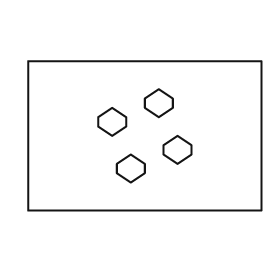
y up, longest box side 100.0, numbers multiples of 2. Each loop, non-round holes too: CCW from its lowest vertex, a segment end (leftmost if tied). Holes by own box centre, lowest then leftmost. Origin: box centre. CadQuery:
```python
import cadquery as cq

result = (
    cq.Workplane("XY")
    .moveTo(-50.0, -32.0)
    .lineTo(50.0, -32.0)
    .lineTo(50.0, 32.0)
    .lineTo(-50.0, 32.0)
    .close()
    .moveTo(-6.0, -20.0)
    .lineTo(0.0, -16.0)
    .lineTo(0.0, -12.0)
    .lineTo(-6.0, -8.0)
    .lineTo(-12.0, -12.0)
    .lineTo(-12.0, -16.0)
    .close()
    .moveTo(14.0, -12.0)
    .lineTo(20.0, -8.0)
    .lineTo(20.0, -4.0)
    .lineTo(14.0, 0.0)
    .lineTo(8.0, -4.0)
    .lineTo(8.0, -8.0)
    .close()
    .moveTo(-14.0, 0.0)
    .lineTo(-8.0, 4.0)
    .lineTo(-8.0, 8.0)
    .lineTo(-14.0, 12.0)
    .lineTo(-20.0, 8.0)
    .lineTo(-20.0, 4.0)
    .close()
    .moveTo(6.0, 8.0)
    .lineTo(12.0, 12.0)
    .lineTo(12.0, 16.0)
    .lineTo(6.0, 20.0)
    .lineTo(0.0, 16.0)
    .lineTo(0.0, 12.0)
    .close()
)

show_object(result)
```